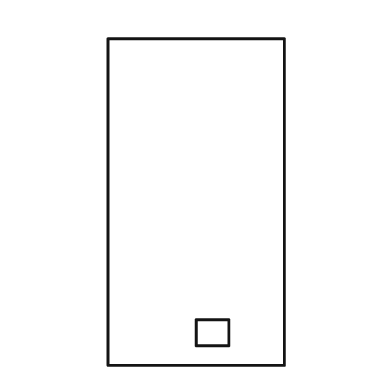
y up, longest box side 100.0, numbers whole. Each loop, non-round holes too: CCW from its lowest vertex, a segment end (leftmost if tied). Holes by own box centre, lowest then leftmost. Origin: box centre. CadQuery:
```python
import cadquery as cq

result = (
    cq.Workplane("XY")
    .moveTo(-27.0, -50.0)
    .lineTo(27.0, -50.0)
    .lineTo(27.0, 50.0)
    .lineTo(-27.0, 50.0)
    .close()
    .moveTo(0.0, -44.0)
    .lineTo(10.0, -44.0)
    .lineTo(10.0, -36.0)
    .lineTo(0.0, -36.0)
    .close()
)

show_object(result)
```